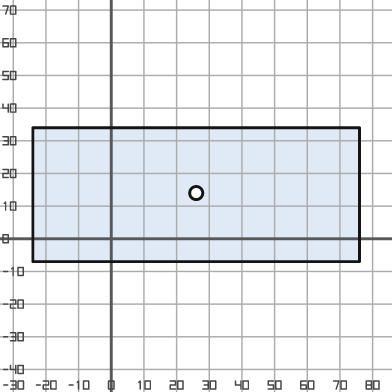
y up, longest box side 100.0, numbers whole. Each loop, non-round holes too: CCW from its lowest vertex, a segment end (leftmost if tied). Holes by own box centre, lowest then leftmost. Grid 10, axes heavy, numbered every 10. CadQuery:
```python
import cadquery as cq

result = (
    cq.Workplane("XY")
    .moveTo(-24.0, -7.0)
    .lineTo(76.0, -7.0)
    .lineTo(76.0, 34.0)
    .lineTo(-24.0, 34.0)
    .close()
    .moveTo(26.0, 14.0)
    .circle(2.0)
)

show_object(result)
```